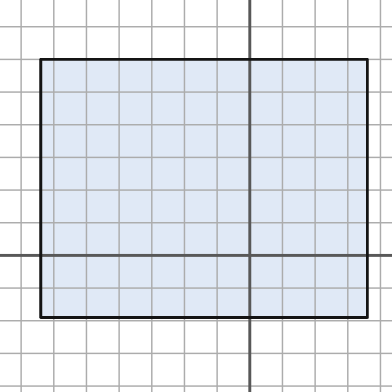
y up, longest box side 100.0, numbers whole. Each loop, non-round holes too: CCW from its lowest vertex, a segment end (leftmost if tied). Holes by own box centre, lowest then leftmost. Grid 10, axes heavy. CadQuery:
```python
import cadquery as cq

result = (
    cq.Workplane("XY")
    .moveTo(-64.0, -19.0)
    .lineTo(36.0, -19.0)
    .lineTo(36.0, 60.0)
    .lineTo(-64.0, 60.0)
    .close()
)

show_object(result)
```